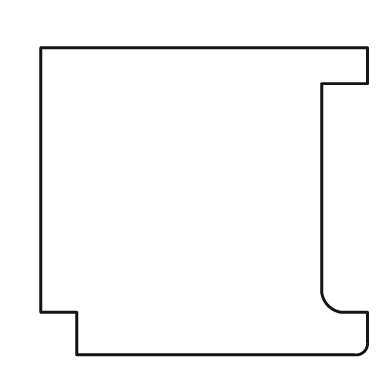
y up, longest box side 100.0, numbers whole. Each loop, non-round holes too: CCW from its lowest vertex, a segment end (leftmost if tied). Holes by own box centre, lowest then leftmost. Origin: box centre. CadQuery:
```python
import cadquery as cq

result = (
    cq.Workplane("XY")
    .moveTo(-39.0, -47.0)
    .lineTo(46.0, -47.0)
    .threePointArc((49.0, -46.0), (50.0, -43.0))
    .lineTo(50.0, -34.0)
    .lineTo(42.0, -34.0)
    .threePointArc((38.0, -32.0), (36.0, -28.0))
    .lineTo(36.0, 36.0)
    .lineTo(50.0, 36.0)
    .lineTo(50.0, 47.0)
    .lineTo(-50.0, 47.0)
    .lineTo(-50.0, -34.0)
    .lineTo(-39.0, -34.0)
    .close()
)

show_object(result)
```